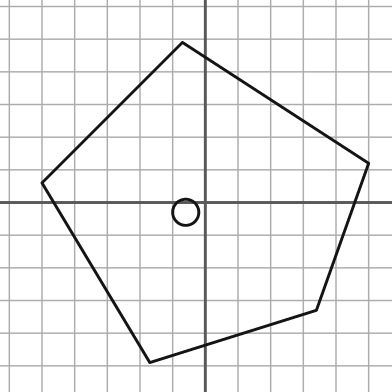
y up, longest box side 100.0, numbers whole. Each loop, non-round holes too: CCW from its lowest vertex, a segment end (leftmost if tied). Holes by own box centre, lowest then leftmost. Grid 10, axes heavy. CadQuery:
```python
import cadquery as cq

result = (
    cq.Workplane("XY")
    .moveTo(-17.0, -49.0)
    .lineTo(34.0, -33.0)
    .lineTo(50.0, 12.0)
    .lineTo(-7.0, 49.0)
    .lineTo(-50.0, 6.0)
    .close()
    .moveTo(-6.0, -3.0)
    .circle(4.0)
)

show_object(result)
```